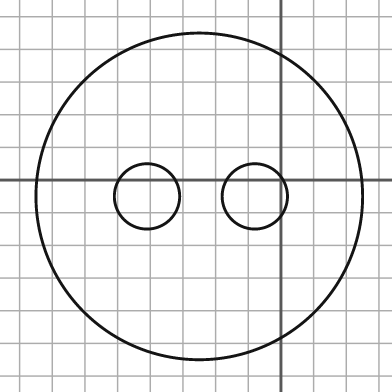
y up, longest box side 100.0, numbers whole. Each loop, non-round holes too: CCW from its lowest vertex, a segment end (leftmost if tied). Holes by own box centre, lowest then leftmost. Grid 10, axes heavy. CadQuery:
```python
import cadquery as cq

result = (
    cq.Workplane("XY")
    .moveTo(-25.0, -5.0)
    .circle(50.0)
    .moveTo(-41.0, -5.0)
    .circle(10.0)
    .moveTo(-8.0, -5.0)
    .circle(10.0)
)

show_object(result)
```